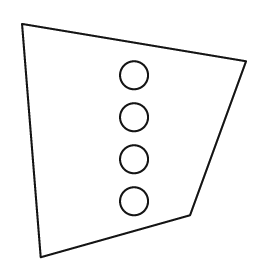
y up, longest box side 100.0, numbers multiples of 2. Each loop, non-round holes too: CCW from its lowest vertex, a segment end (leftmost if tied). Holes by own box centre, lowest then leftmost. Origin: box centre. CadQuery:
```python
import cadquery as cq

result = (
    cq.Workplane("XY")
    .moveTo(-40.0, -50.0)
    .lineTo(24.0, -32.0)
    .lineTo(48.0, 34.0)
    .lineTo(-48.0, 50.0)
    .close()
    .moveTo(0.0, -26.0)
    .circle(6.0)
    .moveTo(0.0, -8.0)
    .circle(6.0)
    .moveTo(0.0, 10.0)
    .circle(6.0)
    .moveTo(0.0, 28.0)
    .circle(6.0)
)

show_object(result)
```